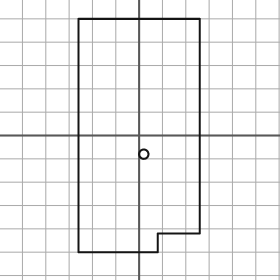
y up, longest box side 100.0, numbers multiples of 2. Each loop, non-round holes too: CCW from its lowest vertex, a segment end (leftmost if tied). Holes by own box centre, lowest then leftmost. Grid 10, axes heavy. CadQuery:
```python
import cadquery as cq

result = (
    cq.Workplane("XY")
    .moveTo(-26.0, -50.0)
    .lineTo(8.0, -50.0)
    .lineTo(8.0, -42.0)
    .lineTo(26.0, -42.0)
    .lineTo(26.0, 50.0)
    .lineTo(-26.0, 50.0)
    .close()
    .moveTo(2.0, -8.0)
    .circle(2.0)
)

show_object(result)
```